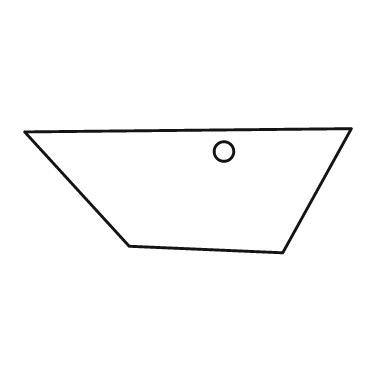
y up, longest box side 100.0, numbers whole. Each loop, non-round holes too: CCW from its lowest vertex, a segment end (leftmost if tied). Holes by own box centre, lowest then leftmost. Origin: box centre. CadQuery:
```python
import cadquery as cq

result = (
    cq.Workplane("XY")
    .moveTo(29.0, -19.0)
    .lineTo(50.0, 19.0)
    .lineTo(-50.0, 18.0)
    .lineTo(-18.0, -17.0)
    .close()
    .moveTo(11.0, 12.0)
    .circle(3.0)
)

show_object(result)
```